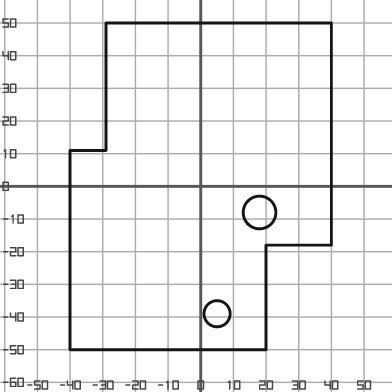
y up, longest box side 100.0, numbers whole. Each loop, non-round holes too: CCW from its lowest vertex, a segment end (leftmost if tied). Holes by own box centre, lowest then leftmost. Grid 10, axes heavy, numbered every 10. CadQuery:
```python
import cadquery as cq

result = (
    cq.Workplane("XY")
    .moveTo(-40.0, -50.0)
    .lineTo(20.0, -50.0)
    .lineTo(20.0, -18.0)
    .lineTo(40.0, -18.0)
    .lineTo(40.0, 50.0)
    .lineTo(-29.0, 50.0)
    .lineTo(-29.0, 11.0)
    .lineTo(-40.0, 11.0)
    .close()
    .moveTo(5.0, -39.0)
    .circle(4.0)
    .moveTo(18.0, -8.0)
    .circle(5.0)
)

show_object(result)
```